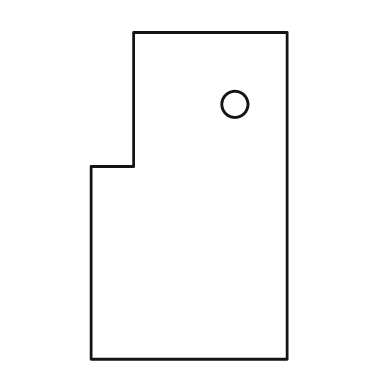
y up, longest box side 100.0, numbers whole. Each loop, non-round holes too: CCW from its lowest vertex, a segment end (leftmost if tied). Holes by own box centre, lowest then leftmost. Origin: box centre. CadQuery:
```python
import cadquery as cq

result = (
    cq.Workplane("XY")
    .moveTo(-30.0, -50.0)
    .lineTo(30.0, -50.0)
    .lineTo(30.0, 50.0)
    .lineTo(-17.0, 50.0)
    .lineTo(-17.0, 9.0)
    .lineTo(-30.0, 9.0)
    .close()
    .moveTo(14.0, 28.0)
    .circle(4.0)
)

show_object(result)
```